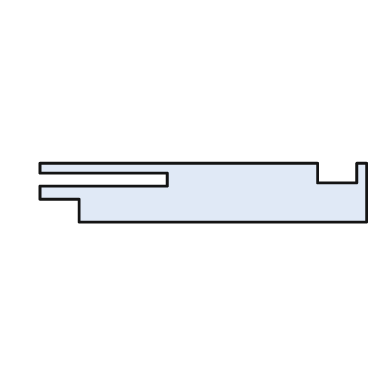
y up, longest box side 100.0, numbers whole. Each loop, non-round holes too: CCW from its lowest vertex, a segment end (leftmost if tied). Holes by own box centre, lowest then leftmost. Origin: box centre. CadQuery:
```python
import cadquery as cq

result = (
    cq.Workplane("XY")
    .moveTo(-38.0, -9.0)
    .lineTo(50.0, -9.0)
    .lineTo(50.0, 9.0)
    .lineTo(47.0, 9.0)
    .lineTo(47.0, 3.0)
    .lineTo(35.0, 3.0)
    .lineTo(35.0, 9.0)
    .lineTo(-50.0, 9.0)
    .lineTo(-50.0, 6.0)
    .lineTo(-11.0, 6.0)
    .lineTo(-11.0, 2.0)
    .lineTo(-50.0, 2.0)
    .lineTo(-50.0, -2.0)
    .lineTo(-38.0, -2.0)
    .close()
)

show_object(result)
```